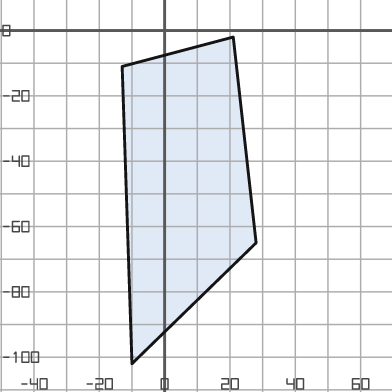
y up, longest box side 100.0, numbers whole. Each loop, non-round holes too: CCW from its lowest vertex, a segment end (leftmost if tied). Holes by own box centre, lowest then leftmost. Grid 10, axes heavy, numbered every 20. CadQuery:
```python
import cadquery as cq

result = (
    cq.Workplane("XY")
    .moveTo(-10.0, -102.0)
    .lineTo(28.0, -65.0)
    .lineTo(21.0, -2.0)
    .lineTo(-13.0, -11.0)
    .close()
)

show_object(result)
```